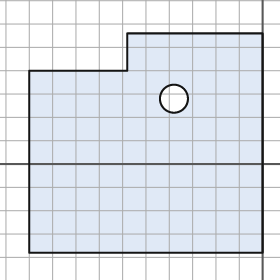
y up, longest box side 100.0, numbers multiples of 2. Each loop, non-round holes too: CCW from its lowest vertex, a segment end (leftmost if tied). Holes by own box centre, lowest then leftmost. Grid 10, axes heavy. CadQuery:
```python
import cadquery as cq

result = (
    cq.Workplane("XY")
    .moveTo(-100.0, -38.0)
    .lineTo(0.0, -38.0)
    .lineTo(0.0, 56.0)
    .lineTo(-58.0, 56.0)
    .lineTo(-58.0, 40.0)
    .lineTo(-100.0, 40.0)
    .close()
    .moveTo(-38.0, 28.0)
    .circle(6.0)
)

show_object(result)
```